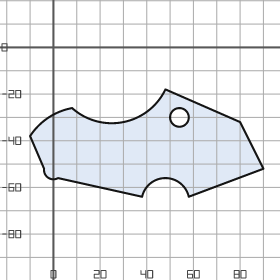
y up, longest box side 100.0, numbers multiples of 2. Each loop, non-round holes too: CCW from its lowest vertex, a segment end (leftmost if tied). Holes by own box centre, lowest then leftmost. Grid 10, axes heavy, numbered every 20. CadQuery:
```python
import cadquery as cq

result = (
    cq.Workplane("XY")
    .moveTo(38.0, -64.0)
    .threePointArc((48.0, -56.0), (58.0, -64.0))
    .lineTo(90.0, -52.0)
    .lineTo(80.0, -32.0)
    .lineTo(48.0, -18.0)
    .threePointArc((30.0, -32.0), (8.0, -26.0))
    .threePointArc((-2.0, -30.0), (-10.0, -38.0))
    .lineTo(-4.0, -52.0)
    .threePointArc((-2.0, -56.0), (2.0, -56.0))
    .close()
    .moveTo(54.0, -30.0)
    .circle(4.0)
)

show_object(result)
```